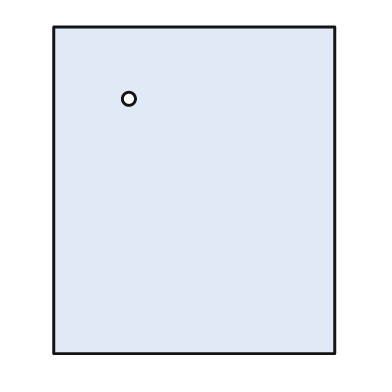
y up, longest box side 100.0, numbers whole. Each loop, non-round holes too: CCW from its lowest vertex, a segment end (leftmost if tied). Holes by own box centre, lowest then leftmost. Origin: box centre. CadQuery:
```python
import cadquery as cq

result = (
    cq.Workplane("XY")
    .moveTo(-43.0, -50.0)
    .lineTo(43.0, -50.0)
    .lineTo(43.0, 50.0)
    .lineTo(-43.0, 50.0)
    .close()
    .moveTo(-20.0, 28.0)
    .circle(2.0)
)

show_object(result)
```